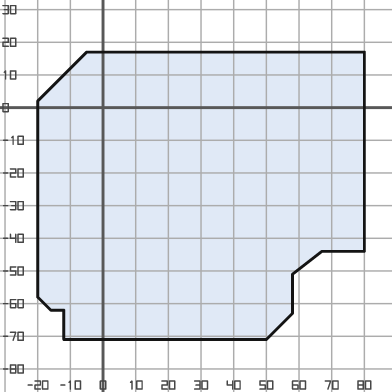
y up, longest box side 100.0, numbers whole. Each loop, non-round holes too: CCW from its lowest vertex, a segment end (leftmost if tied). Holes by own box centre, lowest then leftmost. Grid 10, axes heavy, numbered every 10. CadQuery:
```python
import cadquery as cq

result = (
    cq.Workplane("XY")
    .moveTo(-12.0, -71.0)
    .lineTo(50.0, -71.0)
    .lineTo(58.0, -63.0)
    .lineTo(58.0, -51.0)
    .lineTo(67.0, -44.0)
    .lineTo(80.0, -44.0)
    .lineTo(80.0, 17.0)
    .lineTo(-5.0, 17.0)
    .lineTo(-20.0, 2.0)
    .lineTo(-20.0, -58.0)
    .lineTo(-16.0, -62.0)
    .lineTo(-12.0, -62.0)
    .close()
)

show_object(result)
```